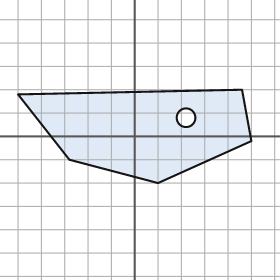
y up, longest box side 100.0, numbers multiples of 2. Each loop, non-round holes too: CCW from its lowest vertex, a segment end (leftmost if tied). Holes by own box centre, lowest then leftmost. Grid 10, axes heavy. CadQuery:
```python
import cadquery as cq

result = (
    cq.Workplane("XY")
    .moveTo(10.0, -20.0)
    .lineTo(50.0, -2.0)
    .lineTo(46.0, 20.0)
    .lineTo(-50.0, 18.0)
    .lineTo(-28.0, -10.0)
    .close()
    .moveTo(22.0, 8.0)
    .circle(4.0)
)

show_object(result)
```